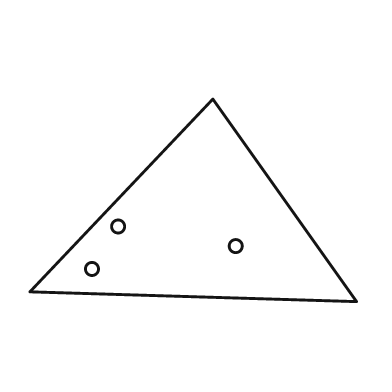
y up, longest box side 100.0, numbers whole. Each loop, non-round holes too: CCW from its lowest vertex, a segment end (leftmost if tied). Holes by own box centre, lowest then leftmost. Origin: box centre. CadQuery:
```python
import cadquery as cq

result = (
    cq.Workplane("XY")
    .moveTo(50.0, -31.0)
    .lineTo(6.0, 31.0)
    .lineTo(-50.0, -28.0)
    .close()
    .moveTo(-31.0, -21.0)
    .circle(2.0)
    .moveTo(13.0, -14.0)
    .circle(2.0)
    .moveTo(-23.0, -8.0)
    .circle(2.0)
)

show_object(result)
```